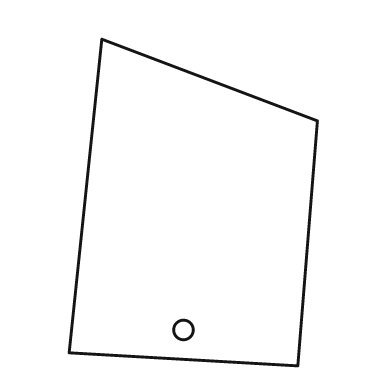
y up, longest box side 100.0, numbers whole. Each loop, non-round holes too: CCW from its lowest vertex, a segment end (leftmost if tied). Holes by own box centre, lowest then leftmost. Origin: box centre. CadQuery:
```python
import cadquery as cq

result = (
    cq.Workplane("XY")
    .moveTo(32.0, -50.0)
    .lineTo(38.0, 25.0)
    .lineTo(-28.0, 50.0)
    .lineTo(-38.0, -46.0)
    .close()
    .moveTo(-3.0, -39.0)
    .circle(3.0)
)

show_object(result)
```